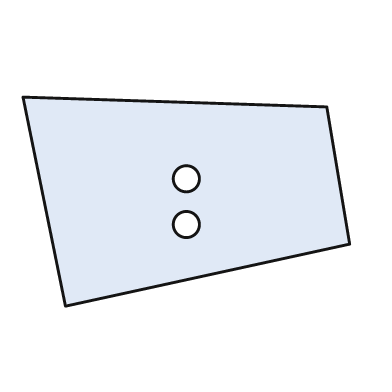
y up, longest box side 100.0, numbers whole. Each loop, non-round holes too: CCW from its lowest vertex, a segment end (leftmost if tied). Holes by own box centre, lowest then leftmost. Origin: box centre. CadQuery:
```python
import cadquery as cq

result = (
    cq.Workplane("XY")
    .moveTo(-37.0, -32.0)
    .lineTo(50.0, -13.0)
    .lineTo(43.0, 29.0)
    .lineTo(-50.0, 32.0)
    .close()
    .moveTo(0.0, -7.0)
    .circle(4.0)
    .moveTo(0.0, 7.0)
    .circle(4.0)
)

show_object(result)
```